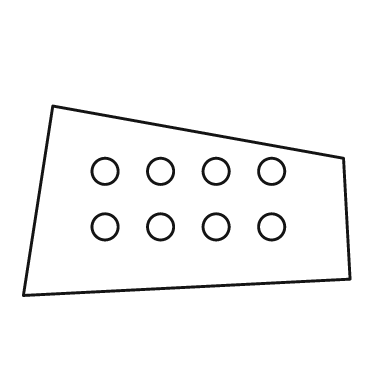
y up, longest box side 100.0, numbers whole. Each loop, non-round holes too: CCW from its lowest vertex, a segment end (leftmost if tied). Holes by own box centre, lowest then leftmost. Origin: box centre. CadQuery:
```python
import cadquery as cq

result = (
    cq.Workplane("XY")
    .moveTo(-50.0, -29.0)
    .lineTo(50.0, -24.0)
    .lineTo(48.0, 13.0)
    .lineTo(-41.0, 29.0)
    .close()
    .moveTo(-25.0, -8.0)
    .circle(4.0)
    .moveTo(-8.0, -8.0)
    .circle(4.0)
    .moveTo(9.0, -8.0)
    .circle(4.0)
    .moveTo(26.0, -8.0)
    .circle(4.0)
    .moveTo(-25.0, 9.0)
    .circle(4.0)
    .moveTo(-8.0, 9.0)
    .circle(4.0)
    .moveTo(9.0, 9.0)
    .circle(4.0)
    .moveTo(26.0, 9.0)
    .circle(4.0)
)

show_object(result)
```